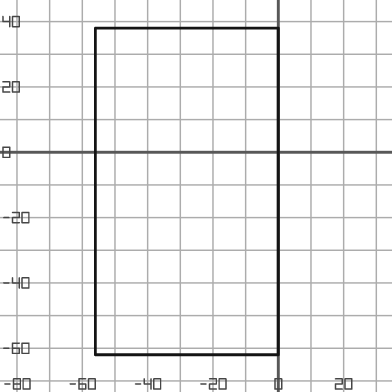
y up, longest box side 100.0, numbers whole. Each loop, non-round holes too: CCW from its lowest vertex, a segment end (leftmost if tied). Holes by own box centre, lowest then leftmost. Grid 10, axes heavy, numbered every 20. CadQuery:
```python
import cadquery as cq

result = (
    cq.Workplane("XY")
    .moveTo(-56.0, -62.0)
    .lineTo(0.0, -62.0)
    .lineTo(0.0, 38.0)
    .lineTo(-56.0, 38.0)
    .close()
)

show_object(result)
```